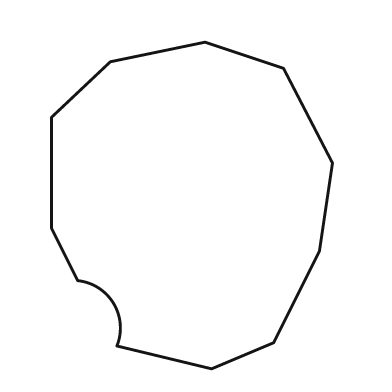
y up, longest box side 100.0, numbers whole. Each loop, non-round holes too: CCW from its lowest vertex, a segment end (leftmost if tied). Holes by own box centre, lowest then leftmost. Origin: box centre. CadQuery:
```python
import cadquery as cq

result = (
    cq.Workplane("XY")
    .moveTo(6.0, -50.0)
    .lineTo(25.0, -42.0)
    .lineTo(39.0, -14.0)
    .lineTo(43.0, 13.0)
    .lineTo(28.0, 42.0)
    .lineTo(4.0, 50.0)
    .lineTo(-25.0, 44.0)
    .lineTo(-43.0, 27.0)
    .lineTo(-43.0, -7.0)
    .lineTo(-35.0, -23.0)
    .threePointArc((-24.0, -30.0), (-23.0, -43.0))
    .close()
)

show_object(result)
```